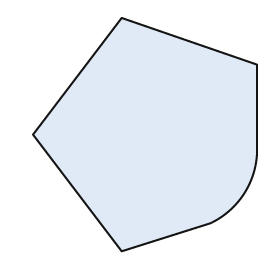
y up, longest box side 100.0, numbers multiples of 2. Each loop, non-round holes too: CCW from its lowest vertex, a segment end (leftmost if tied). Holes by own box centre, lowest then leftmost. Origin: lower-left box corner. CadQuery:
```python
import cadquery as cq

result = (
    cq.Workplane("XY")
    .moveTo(38.0, 0.0)
    .lineTo(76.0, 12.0)
    .threePointArc((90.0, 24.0), (96.0, 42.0))
    .lineTo(96.0, 80.0)
    .lineTo(38.0, 100.0)
    .lineTo(0.0, 50.0)
    .close()
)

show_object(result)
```